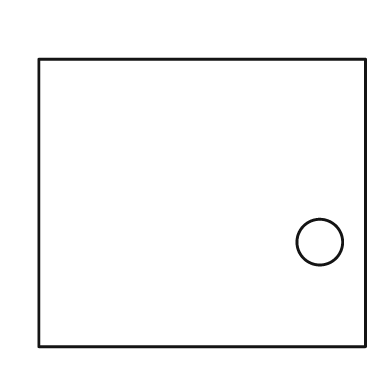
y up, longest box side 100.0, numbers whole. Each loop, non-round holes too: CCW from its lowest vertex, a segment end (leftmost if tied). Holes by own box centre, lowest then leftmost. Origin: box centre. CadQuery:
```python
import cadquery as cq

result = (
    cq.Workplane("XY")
    .moveTo(-50.0, -44.0)
    .lineTo(50.0, -44.0)
    .lineTo(50.0, 44.0)
    .lineTo(-50.0, 44.0)
    .close()
    .moveTo(36.0, -12.0)
    .circle(7.0)
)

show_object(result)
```